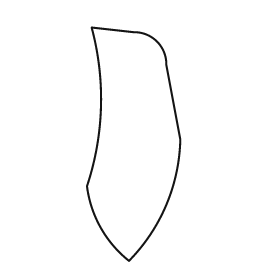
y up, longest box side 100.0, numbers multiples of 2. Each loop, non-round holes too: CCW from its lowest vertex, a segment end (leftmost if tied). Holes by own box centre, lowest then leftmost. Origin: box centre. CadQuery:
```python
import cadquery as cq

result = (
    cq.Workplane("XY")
    .moveTo(-2.0, -50.0)
    .threePointArc((14.0, -26.0), (20.0, 2.0))
    .lineTo(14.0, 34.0)
    .threePointArc((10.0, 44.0), (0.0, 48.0))
    .lineTo(-18.0, 50.0)
    .threePointArc((-14.0, 16.0), (-20.0, -18.0))
    .threePointArc((-14.0, -36.0), (-2.0, -50.0))
    .close()
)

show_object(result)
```